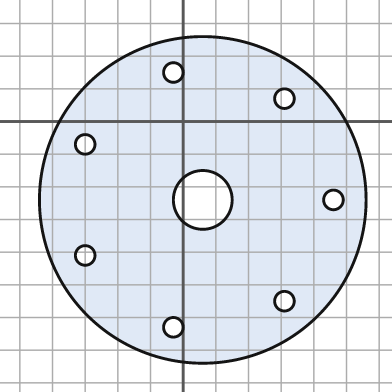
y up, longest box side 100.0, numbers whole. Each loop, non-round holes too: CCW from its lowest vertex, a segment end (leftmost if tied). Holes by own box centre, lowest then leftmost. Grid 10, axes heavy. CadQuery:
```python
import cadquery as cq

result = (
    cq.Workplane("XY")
    .moveTo(6.0, -24.0)
    .circle(50.0)
    .moveTo(-3.0, -63.0)
    .circle(3.0)
    .moveTo(31.0, -55.0)
    .circle(3.0)
    .moveTo(-30.0, -41.0)
    .circle(3.0)
    .moveTo(6.0, -24.0)
    .circle(9.0)
    .moveTo(46.0, -24.0)
    .circle(3.0)
    .moveTo(-30.0, -7.0)
    .circle(3.0)
    .moveTo(31.0, 7.0)
    .circle(3.0)
    .moveTo(-3.0, 15.0)
    .circle(3.0)
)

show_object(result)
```